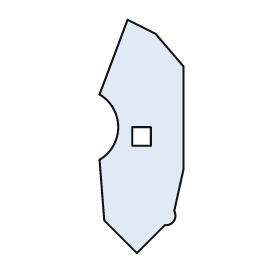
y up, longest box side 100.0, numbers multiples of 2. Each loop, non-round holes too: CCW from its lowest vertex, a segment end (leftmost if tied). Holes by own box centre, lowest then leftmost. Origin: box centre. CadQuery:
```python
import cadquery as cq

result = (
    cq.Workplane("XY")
    .moveTo(-2.0, -50.0)
    .lineTo(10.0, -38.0)
    .threePointArc((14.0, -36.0), (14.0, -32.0))
    .lineTo(18.0, -14.0)
    .lineTo(18.0, 30.0)
    .lineTo(6.0, 44.0)
    .lineTo(-6.0, 50.0)
    .lineTo(-18.0, 18.0)
    .threePointArc((-10.0, 4.0), (-18.0, -10.0))
    .lineTo(-16.0, -36.0)
    .close()
    .moveTo(-4.0, -4.0)
    .lineTo(4.0, -4.0)
    .lineTo(4.0, 4.0)
    .lineTo(-4.0, 4.0)
    .close()
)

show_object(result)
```